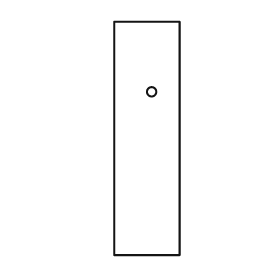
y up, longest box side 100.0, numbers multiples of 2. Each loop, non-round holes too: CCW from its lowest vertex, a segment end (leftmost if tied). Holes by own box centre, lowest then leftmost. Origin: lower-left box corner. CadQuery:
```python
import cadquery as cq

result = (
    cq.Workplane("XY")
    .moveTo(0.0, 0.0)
    .lineTo(28.0, 0.0)
    .lineTo(28.0, 100.0)
    .lineTo(0.0, 100.0)
    .close()
    .moveTo(16.0, 70.0)
    .circle(2.0)
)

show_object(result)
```